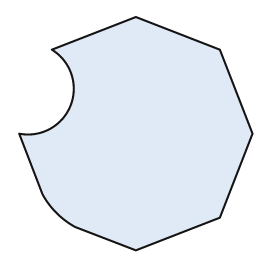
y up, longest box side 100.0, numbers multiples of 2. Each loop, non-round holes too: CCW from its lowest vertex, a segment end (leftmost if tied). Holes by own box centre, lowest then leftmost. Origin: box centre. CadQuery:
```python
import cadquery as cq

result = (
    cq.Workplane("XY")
    .moveTo(0.0, -50.0)
    .lineTo(36.0, -36.0)
    .lineTo(50.0, 0.0)
    .lineTo(36.0, 36.0)
    .lineTo(0.0, 50.0)
    .lineTo(-36.0, 36.0)
    .threePointArc((-28.0, 12.0), (-50.0, 0.0))
    .lineTo(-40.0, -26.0)
    .threePointArc((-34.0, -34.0), (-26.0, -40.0))
    .close()
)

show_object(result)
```